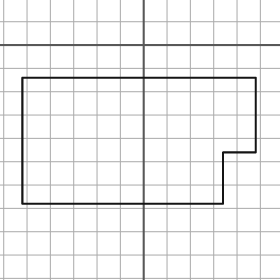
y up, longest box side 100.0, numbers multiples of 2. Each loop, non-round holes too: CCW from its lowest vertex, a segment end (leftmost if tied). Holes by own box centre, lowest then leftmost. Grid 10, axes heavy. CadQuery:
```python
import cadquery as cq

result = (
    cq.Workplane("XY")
    .moveTo(-52.0, -68.0)
    .lineTo(34.0, -68.0)
    .lineTo(34.0, -46.0)
    .lineTo(48.0, -46.0)
    .lineTo(48.0, -14.0)
    .lineTo(-52.0, -14.0)
    .close()
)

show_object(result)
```